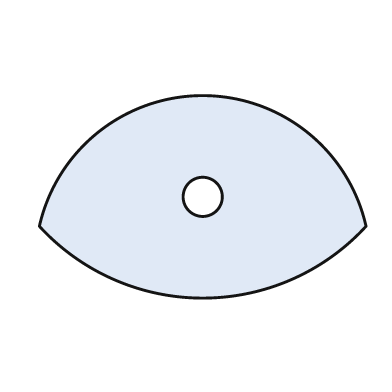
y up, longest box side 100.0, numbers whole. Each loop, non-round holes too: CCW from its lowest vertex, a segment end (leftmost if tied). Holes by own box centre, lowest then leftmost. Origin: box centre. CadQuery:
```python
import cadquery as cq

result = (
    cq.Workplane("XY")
    .moveTo(-50.0, -9.0)
    .threePointArc((0.0, -31.0), (50.0, -9.0))
    .threePointArc((0.0, 31.0), (-50.0, -9.0))
    .close()
    .moveTo(0.0, 0.0)
    .circle(6.0)
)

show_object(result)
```